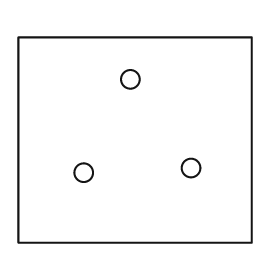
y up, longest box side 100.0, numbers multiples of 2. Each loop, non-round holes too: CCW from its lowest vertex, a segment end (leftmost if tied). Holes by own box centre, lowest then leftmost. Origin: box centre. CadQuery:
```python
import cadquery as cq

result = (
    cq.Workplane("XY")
    .moveTo(-50.0, -44.0)
    .lineTo(50.0, -44.0)
    .lineTo(50.0, 44.0)
    .lineTo(-50.0, 44.0)
    .close()
    .moveTo(-22.0, -14.0)
    .circle(4.0)
    .moveTo(24.0, -12.0)
    .circle(4.0)
    .moveTo(-2.0, 26.0)
    .circle(4.0)
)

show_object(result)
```